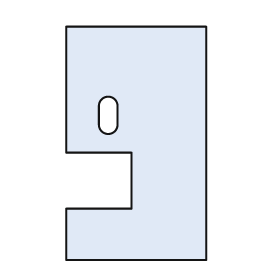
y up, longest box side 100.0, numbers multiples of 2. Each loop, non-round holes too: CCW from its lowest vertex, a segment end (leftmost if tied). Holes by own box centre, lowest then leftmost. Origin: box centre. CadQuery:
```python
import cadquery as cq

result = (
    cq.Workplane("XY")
    .moveTo(-30.0, -50.0)
    .lineTo(30.0, -50.0)
    .lineTo(30.0, 50.0)
    .lineTo(-30.0, 50.0)
    .lineTo(-30.0, -4.0)
    .lineTo(-2.0, -4.0)
    .lineTo(-2.0, -28.0)
    .lineTo(-30.0, -28.0)
    .close()
    .moveTo(-16.0, 8.0)
    .threePointArc((-12.0, 4.0), (-8.0, 8.0))
    .lineTo(-8.0, 16.0)
    .threePointArc((-12.0, 20.0), (-16.0, 16.0))
    .close()
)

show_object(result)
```